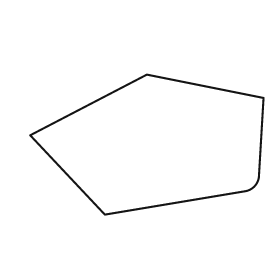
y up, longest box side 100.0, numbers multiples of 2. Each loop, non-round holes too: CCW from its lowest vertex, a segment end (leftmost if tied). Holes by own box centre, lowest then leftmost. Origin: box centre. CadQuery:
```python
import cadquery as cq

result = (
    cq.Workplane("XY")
    .moveTo(-18.0, -30.0)
    .lineTo(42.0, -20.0)
    .threePointArc((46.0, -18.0), (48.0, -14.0))
    .lineTo(50.0, 20.0)
    .lineTo(0.0, 30.0)
    .lineTo(-50.0, 4.0)
    .close()
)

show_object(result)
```